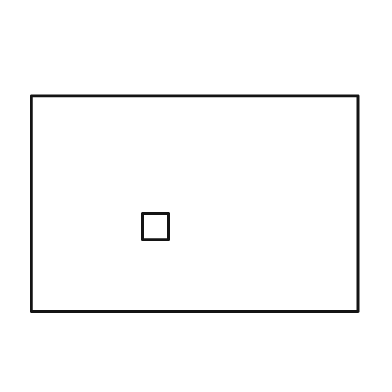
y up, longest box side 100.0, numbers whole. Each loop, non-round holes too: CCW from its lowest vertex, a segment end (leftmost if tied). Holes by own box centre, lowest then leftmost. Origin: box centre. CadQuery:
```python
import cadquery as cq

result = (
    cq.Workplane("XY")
    .moveTo(-50.0, -33.0)
    .lineTo(50.0, -33.0)
    .lineTo(50.0, 33.0)
    .lineTo(-50.0, 33.0)
    .close()
    .moveTo(-16.0, -11.0)
    .lineTo(-8.0, -11.0)
    .lineTo(-8.0, -3.0)
    .lineTo(-16.0, -3.0)
    .close()
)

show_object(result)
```